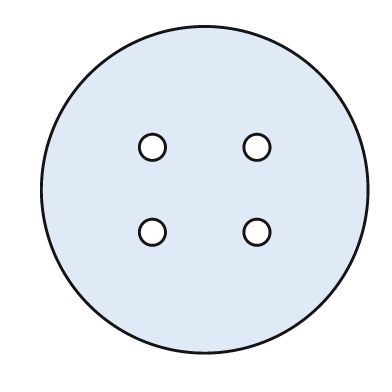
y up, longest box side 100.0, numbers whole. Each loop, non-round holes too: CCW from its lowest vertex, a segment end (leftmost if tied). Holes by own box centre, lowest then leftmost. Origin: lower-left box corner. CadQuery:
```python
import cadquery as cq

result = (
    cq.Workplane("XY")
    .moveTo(50.0, 50.0)
    .circle(50.0)
    .moveTo(34.0, 37.0)
    .circle(4.0)
    .moveTo(66.0, 37.0)
    .circle(4.0)
    .moveTo(34.0, 63.0)
    .circle(4.0)
    .moveTo(66.0, 63.0)
    .circle(4.0)
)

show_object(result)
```